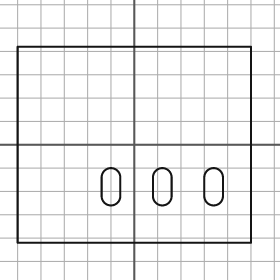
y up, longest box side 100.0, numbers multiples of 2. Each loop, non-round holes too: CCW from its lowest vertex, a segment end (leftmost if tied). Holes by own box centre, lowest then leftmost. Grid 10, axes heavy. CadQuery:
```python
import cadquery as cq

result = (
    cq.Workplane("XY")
    .moveTo(-50.0, -42.0)
    .lineTo(50.0, -42.0)
    .lineTo(50.0, 42.0)
    .lineTo(-50.0, 42.0)
    .close()
    .moveTo(-14.0, -22.0)
    .threePointArc((-10.0, -26.0), (-6.0, -22.0))
    .lineTo(-6.0, -14.0)
    .threePointArc((-10.0, -10.0), (-14.0, -14.0))
    .close()
    .moveTo(8.0, -22.0)
    .threePointArc((12.0, -26.0), (16.0, -22.0))
    .lineTo(16.0, -14.0)
    .threePointArc((12.0, -10.0), (8.0, -14.0))
    .close()
    .moveTo(30.0, -22.0)
    .threePointArc((34.0, -26.0), (38.0, -22.0))
    .lineTo(38.0, -14.0)
    .threePointArc((34.0, -10.0), (30.0, -14.0))
    .close()
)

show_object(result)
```